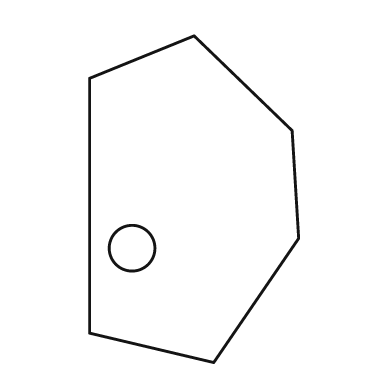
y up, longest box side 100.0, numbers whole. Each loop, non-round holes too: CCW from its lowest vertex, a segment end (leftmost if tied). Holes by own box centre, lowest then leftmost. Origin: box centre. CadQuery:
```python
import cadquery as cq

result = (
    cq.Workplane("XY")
    .moveTo(6.0, -50.0)
    .lineTo(32.0, -12.0)
    .lineTo(30.0, 21.0)
    .lineTo(0.0, 50.0)
    .lineTo(-32.0, 37.0)
    .lineTo(-32.0, -41.0)
    .close()
    .moveTo(-19.0, -15.0)
    .circle(7.0)
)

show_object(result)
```